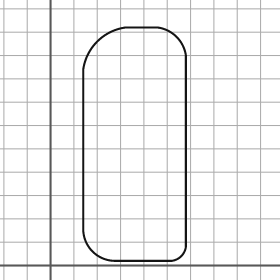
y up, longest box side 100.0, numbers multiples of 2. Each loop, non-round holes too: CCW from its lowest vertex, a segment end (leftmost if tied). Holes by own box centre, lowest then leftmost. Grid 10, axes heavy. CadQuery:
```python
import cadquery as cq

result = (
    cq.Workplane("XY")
    .moveTo(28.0, 2.0)
    .lineTo(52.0, 2.0)
    .threePointArc((56.0, 4.0), (58.0, 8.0))
    .lineTo(58.0, 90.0)
    .threePointArc((54.0, 98.0), (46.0, 102.0))
    .lineTo(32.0, 102.0)
    .threePointArc((20.0, 96.0), (14.0, 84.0))
    .lineTo(14.0, 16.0)
    .threePointArc((18.0, 6.0), (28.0, 2.0))
    .close()
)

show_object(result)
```